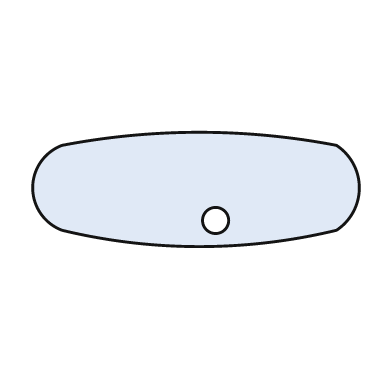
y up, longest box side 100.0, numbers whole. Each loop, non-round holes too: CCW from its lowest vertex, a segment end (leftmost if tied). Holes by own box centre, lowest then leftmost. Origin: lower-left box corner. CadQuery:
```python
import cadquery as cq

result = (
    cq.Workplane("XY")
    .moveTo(9.0, 5.0)
    .threePointArc((51.0, 0.0), (93.0, 5.0))
    .threePointArc((100.0, 18.0), (93.0, 31.0))
    .threePointArc((51.0, 35.0), (9.0, 31.0))
    .threePointArc((0.0, 18.0), (9.0, 5.0))
    .close()
    .moveTo(56.0, 8.0)
    .circle(4.0)
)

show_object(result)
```